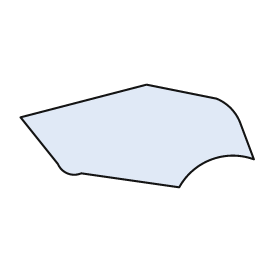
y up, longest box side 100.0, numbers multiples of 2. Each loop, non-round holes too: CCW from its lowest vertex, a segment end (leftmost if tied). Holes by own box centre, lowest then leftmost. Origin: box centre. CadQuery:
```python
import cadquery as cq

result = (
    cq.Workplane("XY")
    .moveTo(18.0, -22.0)
    .threePointArc((32.0, -10.0), (50.0, -10.0))
    .lineTo(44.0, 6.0)
    .threePointArc((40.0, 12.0), (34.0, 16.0))
    .lineTo(4.0, 22.0)
    .lineTo(-50.0, 8.0)
    .lineTo(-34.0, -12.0)
    .threePointArc((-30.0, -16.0), (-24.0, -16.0))
    .close()
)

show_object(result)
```